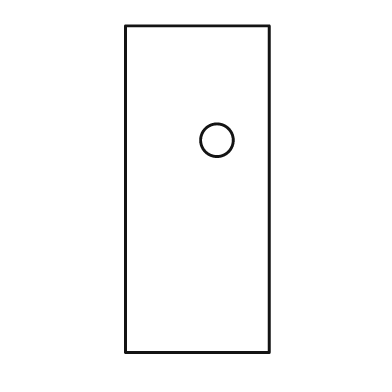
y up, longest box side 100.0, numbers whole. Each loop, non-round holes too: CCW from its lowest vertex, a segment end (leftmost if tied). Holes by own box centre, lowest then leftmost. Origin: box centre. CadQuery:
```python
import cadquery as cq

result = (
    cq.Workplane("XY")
    .moveTo(-22.0, -50.0)
    .lineTo(22.0, -50.0)
    .lineTo(22.0, 50.0)
    .lineTo(-22.0, 50.0)
    .close()
    .moveTo(6.0, 15.0)
    .circle(5.0)
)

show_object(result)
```